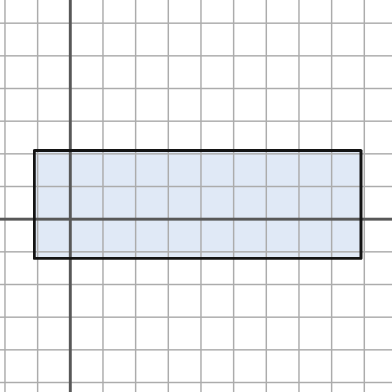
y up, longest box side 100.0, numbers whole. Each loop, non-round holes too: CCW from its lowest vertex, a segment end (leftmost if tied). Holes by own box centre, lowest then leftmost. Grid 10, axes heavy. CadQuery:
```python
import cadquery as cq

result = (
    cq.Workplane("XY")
    .moveTo(-11.0, -12.0)
    .lineTo(89.0, -12.0)
    .lineTo(89.0, 21.0)
    .lineTo(-11.0, 21.0)
    .close()
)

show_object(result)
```